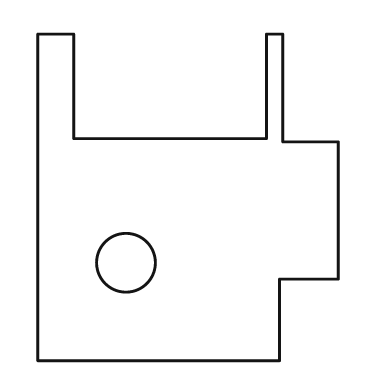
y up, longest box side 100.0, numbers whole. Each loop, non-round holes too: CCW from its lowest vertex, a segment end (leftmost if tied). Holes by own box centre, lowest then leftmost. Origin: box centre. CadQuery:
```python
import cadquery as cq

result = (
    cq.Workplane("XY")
    .moveTo(-46.0, -50.0)
    .lineTo(28.0, -50.0)
    .lineTo(28.0, -25.0)
    .lineTo(46.0, -25.0)
    .lineTo(46.0, 17.0)
    .lineTo(29.0, 17.0)
    .lineTo(29.0, 50.0)
    .lineTo(24.0, 50.0)
    .lineTo(24.0, 18.0)
    .lineTo(-35.0, 18.0)
    .lineTo(-35.0, 50.0)
    .lineTo(-46.0, 50.0)
    .close()
    .moveTo(-19.0, -20.0)
    .circle(9.0)
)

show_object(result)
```